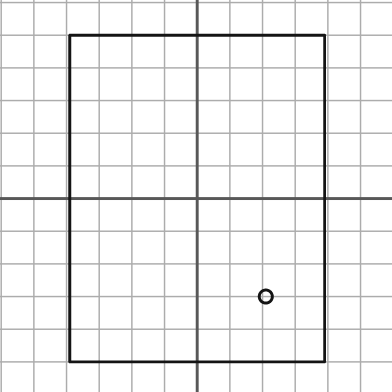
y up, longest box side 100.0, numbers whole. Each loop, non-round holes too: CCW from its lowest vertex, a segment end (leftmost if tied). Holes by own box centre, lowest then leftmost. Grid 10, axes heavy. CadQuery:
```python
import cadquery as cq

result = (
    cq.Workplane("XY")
    .moveTo(-39.0, -50.0)
    .lineTo(39.0, -50.0)
    .lineTo(39.0, 50.0)
    .lineTo(-39.0, 50.0)
    .close()
    .moveTo(21.0, -30.0)
    .circle(2.0)
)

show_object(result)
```